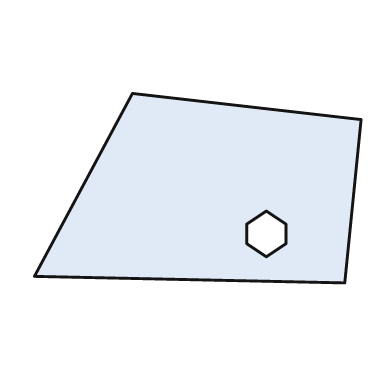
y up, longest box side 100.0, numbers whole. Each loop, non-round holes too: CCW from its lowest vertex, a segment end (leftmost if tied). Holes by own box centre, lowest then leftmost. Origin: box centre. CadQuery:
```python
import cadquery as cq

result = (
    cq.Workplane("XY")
    .moveTo(45.0, -29.0)
    .lineTo(50.0, 21.0)
    .lineTo(-20.0, 29.0)
    .lineTo(-50.0, -27.0)
    .close()
    .moveTo(21.0, -21.0)
    .lineTo(27.0, -17.0)
    .lineTo(27.0, -11.0)
    .lineTo(21.0, -7.0)
    .lineTo(15.0, -11.0)
    .lineTo(15.0, -17.0)
    .close()
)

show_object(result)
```